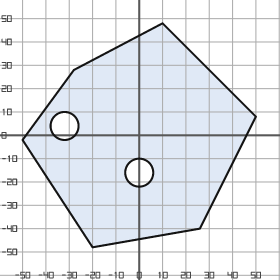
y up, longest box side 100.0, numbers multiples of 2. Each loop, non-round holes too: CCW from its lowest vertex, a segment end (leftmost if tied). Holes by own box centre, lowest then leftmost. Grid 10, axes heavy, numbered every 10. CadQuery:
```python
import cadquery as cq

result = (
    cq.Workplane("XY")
    .moveTo(-20.0, -48.0)
    .lineTo(26.0, -40.0)
    .lineTo(50.0, 8.0)
    .lineTo(10.0, 48.0)
    .lineTo(-28.0, 28.0)
    .lineTo(-50.0, -2.0)
    .close()
    .moveTo(0.0, -16.0)
    .circle(6.0)
    .moveTo(-32.0, 4.0)
    .circle(6.0)
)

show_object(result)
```